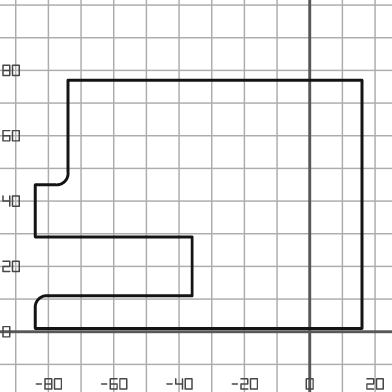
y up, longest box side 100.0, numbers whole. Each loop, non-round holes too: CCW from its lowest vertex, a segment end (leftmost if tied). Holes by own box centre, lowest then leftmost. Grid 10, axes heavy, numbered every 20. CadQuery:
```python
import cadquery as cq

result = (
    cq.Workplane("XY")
    .moveTo(-84.0, 1.0)
    .lineTo(16.0, 1.0)
    .lineTo(16.0, 77.0)
    .lineTo(-74.0, 77.0)
    .lineTo(-74.0, 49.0)
    .threePointArc((-75.0, 46.0), (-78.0, 45.0))
    .lineTo(-84.0, 45.0)
    .lineTo(-84.0, 29.0)
    .lineTo(-36.0, 29.0)
    .lineTo(-36.0, 11.0)
    .lineTo(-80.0, 11.0)
    .threePointArc((-83.0, 10.0), (-84.0, 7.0))
    .close()
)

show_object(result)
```